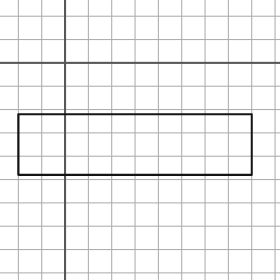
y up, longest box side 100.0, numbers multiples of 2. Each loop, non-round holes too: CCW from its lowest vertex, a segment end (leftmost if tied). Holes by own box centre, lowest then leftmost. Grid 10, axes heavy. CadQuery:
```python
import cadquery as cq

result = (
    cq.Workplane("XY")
    .moveTo(-20.0, -48.0)
    .lineTo(80.0, -48.0)
    .lineTo(80.0, -22.0)
    .lineTo(-20.0, -22.0)
    .close()
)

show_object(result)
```